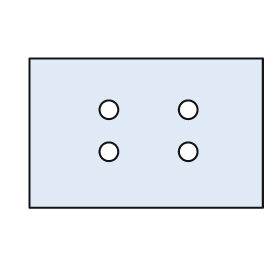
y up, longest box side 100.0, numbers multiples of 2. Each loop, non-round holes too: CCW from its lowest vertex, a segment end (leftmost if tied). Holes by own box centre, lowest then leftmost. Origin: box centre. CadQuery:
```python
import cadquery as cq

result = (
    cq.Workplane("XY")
    .moveTo(-50.0, -32.0)
    .lineTo(50.0, -32.0)
    .lineTo(50.0, 32.0)
    .lineTo(-50.0, 32.0)
    .close()
    .moveTo(-16.0, -8.0)
    .circle(4.0)
    .moveTo(18.0, -8.0)
    .circle(4.0)
    .moveTo(-16.0, 10.0)
    .circle(4.0)
    .moveTo(18.0, 10.0)
    .circle(4.0)
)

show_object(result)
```